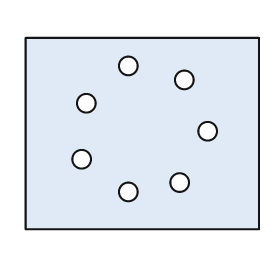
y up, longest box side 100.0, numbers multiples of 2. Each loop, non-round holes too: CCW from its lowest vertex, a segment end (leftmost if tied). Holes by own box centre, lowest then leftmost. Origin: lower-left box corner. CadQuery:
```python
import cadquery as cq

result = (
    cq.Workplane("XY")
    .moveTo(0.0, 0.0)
    .lineTo(100.0, 0.0)
    .lineTo(100.0, 82.0)
    .lineTo(0.0, 82.0)
    .close()
    .moveTo(44.0, 16.0)
    .circle(4.0)
    .moveTo(66.0, 20.0)
    .circle(4.0)
    .moveTo(24.0, 30.0)
    .circle(4.0)
    .moveTo(78.0, 42.0)
    .circle(4.0)
    .moveTo(26.0, 54.0)
    .circle(4.0)
    .moveTo(68.0, 64.0)
    .circle(4.0)
    .moveTo(44.0, 70.0)
    .circle(4.0)
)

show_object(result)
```